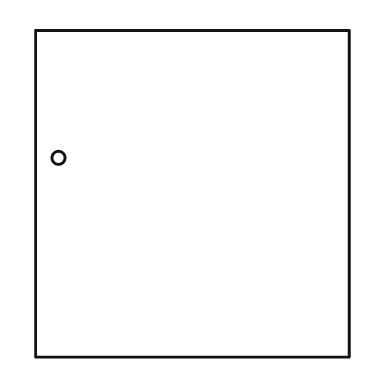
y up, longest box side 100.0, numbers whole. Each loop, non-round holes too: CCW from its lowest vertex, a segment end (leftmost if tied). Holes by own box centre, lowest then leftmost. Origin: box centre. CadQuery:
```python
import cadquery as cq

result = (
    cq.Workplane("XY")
    .moveTo(-48.0, -50.0)
    .lineTo(48.0, -50.0)
    .lineTo(48.0, 50.0)
    .lineTo(-48.0, 50.0)
    .close()
    .moveTo(-41.0, 11.0)
    .circle(2.0)
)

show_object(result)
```